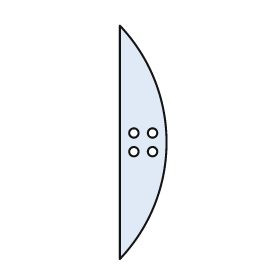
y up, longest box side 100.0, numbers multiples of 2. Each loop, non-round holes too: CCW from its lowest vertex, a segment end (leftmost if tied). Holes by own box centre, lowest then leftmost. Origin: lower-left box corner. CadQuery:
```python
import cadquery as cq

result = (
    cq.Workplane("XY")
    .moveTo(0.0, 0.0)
    .threePointArc((20.0, 50.0), (0.0, 100.0))
    .close()
    .moveTo(6.0, 46.0)
    .circle(2.0)
    .moveTo(14.0, 46.0)
    .circle(2.0)
    .moveTo(6.0, 54.0)
    .circle(2.0)
    .moveTo(14.0, 54.0)
    .circle(2.0)
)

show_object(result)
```